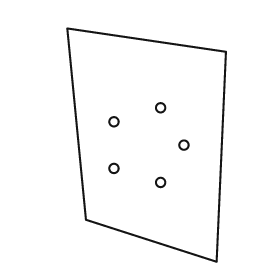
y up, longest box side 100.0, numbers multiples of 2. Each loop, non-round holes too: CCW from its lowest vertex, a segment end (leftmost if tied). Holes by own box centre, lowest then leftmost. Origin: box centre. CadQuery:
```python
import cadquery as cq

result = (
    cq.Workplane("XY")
    .moveTo(30.0, -50.0)
    .lineTo(34.0, 40.0)
    .lineTo(-34.0, 50.0)
    .lineTo(-26.0, -32.0)
    .close()
    .moveTo(6.0, -16.0)
    .circle(2.0)
    .moveTo(-14.0, -10.0)
    .circle(2.0)
    .moveTo(16.0, 0.0)
    .circle(2.0)
    .moveTo(-14.0, 10.0)
    .circle(2.0)
    .moveTo(6.0, 16.0)
    .circle(2.0)
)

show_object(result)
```